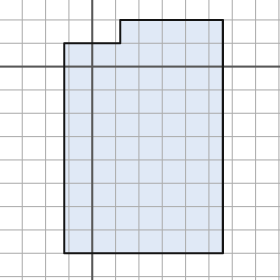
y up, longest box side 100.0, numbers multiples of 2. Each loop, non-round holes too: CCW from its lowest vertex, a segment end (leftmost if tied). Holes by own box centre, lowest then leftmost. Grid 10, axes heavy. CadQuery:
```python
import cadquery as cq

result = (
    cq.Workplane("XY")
    .moveTo(-12.0, -80.0)
    .lineTo(56.0, -80.0)
    .lineTo(56.0, 20.0)
    .lineTo(12.0, 20.0)
    .lineTo(12.0, 10.0)
    .lineTo(-12.0, 10.0)
    .close()
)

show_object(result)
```